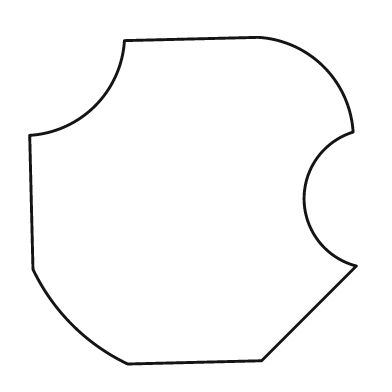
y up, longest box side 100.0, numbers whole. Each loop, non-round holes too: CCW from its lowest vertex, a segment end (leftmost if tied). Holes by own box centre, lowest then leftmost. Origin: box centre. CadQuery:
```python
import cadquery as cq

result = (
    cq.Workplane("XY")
    .moveTo(-20.0, -50.0)
    .lineTo(21.0, -49.0)
    .lineTo(50.0, -20.0)
    .threePointArc((34.0, 0.0), (49.0, 21.0))
    .threePointArc((40.0, 41.0), (20.0, 50.0))
    .lineTo(-21.0, 49.0)
    .threePointArc((-30.0, 29.0), (-50.0, 20.0))
    .lineTo(-49.0, -21.0)
    .threePointArc((-37.0, -38.0), (-20.0, -50.0))
    .close()
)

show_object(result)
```